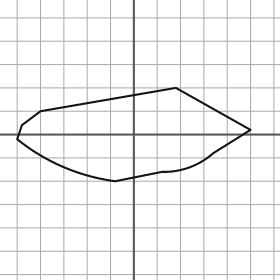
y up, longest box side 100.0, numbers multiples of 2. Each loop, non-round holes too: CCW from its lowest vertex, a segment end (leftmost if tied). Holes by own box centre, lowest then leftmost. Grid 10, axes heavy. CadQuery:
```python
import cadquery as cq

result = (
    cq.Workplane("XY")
    .moveTo(-8.0, -20.0)
    .lineTo(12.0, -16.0)
    .threePointArc((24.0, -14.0), (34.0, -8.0))
    .lineTo(50.0, 2.0)
    .lineTo(18.0, 20.0)
    .lineTo(-40.0, 10.0)
    .lineTo(-48.0, 4.0)
    .lineTo(-50.0, -2.0)
    .threePointArc((-30.0, -14.0), (-8.0, -20.0))
    .close()
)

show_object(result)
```